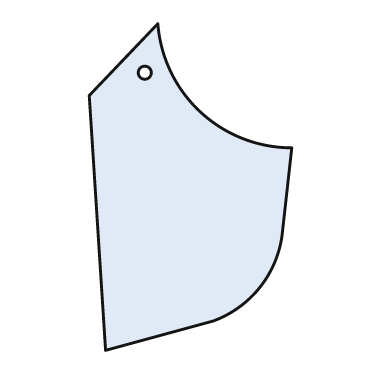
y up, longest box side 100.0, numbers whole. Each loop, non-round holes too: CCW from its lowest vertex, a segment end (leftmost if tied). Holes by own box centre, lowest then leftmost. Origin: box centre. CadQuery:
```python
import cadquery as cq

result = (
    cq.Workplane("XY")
    .moveTo(-26.0, -50.0)
    .lineTo(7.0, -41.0)
    .threePointArc((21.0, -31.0), (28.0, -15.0))
    .lineTo(31.0, 12.0)
    .threePointArc((3.0, 23.0), (-10.0, 50.0))
    .lineTo(-31.0, 28.0)
    .close()
    .moveTo(-14.0, 35.0)
    .circle(2.0)
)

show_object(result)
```